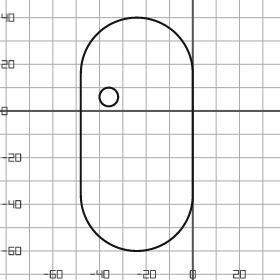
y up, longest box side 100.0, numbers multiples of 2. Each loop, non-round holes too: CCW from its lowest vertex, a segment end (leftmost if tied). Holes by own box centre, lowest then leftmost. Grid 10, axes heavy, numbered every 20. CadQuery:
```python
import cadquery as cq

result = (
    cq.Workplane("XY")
    .moveTo(-48.0, -36.0)
    .threePointArc((-24.0, -60.0), (0.0, -36.0))
    .lineTo(0.0, 16.0)
    .threePointArc((-24.0, 40.0), (-48.0, 16.0))
    .close()
    .moveTo(-36.0, 6.0)
    .circle(4.0)
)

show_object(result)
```